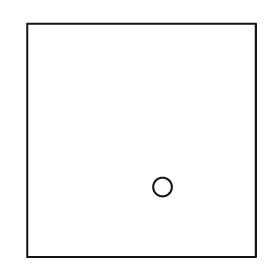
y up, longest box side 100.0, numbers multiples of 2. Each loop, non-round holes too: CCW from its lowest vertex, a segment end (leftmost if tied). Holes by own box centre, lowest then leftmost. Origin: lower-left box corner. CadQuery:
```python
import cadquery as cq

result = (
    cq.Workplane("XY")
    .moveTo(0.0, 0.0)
    .lineTo(98.0, 0.0)
    .lineTo(98.0, 100.0)
    .lineTo(0.0, 100.0)
    .close()
    .moveTo(58.0, 30.0)
    .circle(4.0)
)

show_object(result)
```